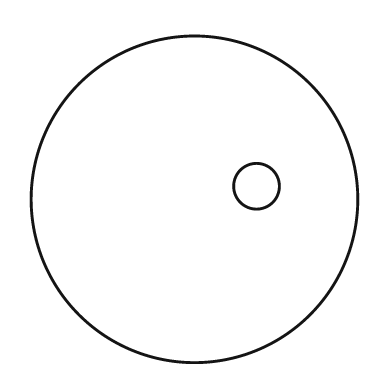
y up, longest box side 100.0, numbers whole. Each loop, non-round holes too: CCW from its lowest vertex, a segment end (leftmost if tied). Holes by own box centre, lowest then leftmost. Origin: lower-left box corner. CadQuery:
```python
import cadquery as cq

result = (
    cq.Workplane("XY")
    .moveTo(50.0, 50.0)
    .circle(50.0)
    .moveTo(69.0, 54.0)
    .circle(7.0)
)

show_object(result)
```